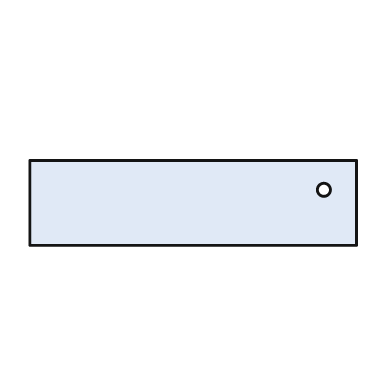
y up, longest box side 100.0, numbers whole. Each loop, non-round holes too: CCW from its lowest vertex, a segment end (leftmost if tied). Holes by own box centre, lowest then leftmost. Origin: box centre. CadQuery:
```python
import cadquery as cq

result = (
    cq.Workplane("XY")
    .moveTo(-50.0, -13.0)
    .lineTo(50.0, -13.0)
    .lineTo(50.0, 13.0)
    .lineTo(-50.0, 13.0)
    .close()
    .moveTo(40.0, 4.0)
    .circle(2.0)
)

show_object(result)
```